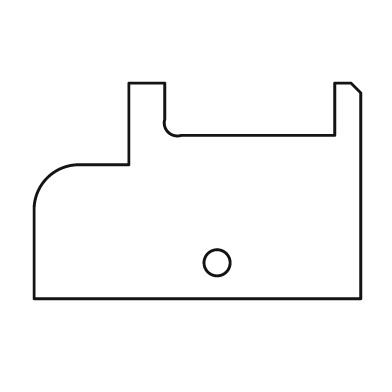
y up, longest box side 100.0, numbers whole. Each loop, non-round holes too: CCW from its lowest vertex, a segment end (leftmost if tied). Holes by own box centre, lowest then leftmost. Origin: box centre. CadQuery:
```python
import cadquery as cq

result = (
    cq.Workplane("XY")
    .moveTo(-50.0, -33.0)
    .lineTo(50.0, -33.0)
    .lineTo(50.0, 30.0)
    .lineTo(47.0, 33.0)
    .lineTo(42.0, 33.0)
    .lineTo(42.0, 17.0)
    .lineTo(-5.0, 17.0)
    .threePointArc((-9.0, 18.0), (-10.0, 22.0))
    .lineTo(-10.0, 33.0)
    .lineTo(-21.0, 33.0)
    .lineTo(-21.0, 8.0)
    .lineTo(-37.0, 8.0)
    .threePointArc((-46.0, 4.0), (-50.0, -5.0))
    .close()
    .moveTo(6.0, -22.0)
    .circle(4.0)
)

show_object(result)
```